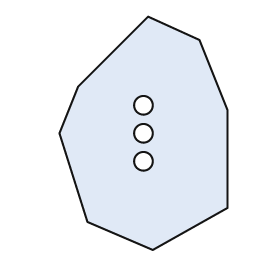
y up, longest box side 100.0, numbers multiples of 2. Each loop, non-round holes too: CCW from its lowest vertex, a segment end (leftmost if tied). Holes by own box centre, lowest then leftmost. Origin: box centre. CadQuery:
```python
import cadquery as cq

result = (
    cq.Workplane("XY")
    .moveTo(4.0, -50.0)
    .lineTo(36.0, -32.0)
    .lineTo(36.0, 10.0)
    .lineTo(24.0, 40.0)
    .lineTo(2.0, 50.0)
    .lineTo(-28.0, 20.0)
    .lineTo(-36.0, 0.0)
    .lineTo(-24.0, -38.0)
    .close()
    .moveTo(0.0, -12.0)
    .circle(4.0)
    .moveTo(0.0, 0.0)
    .circle(4.0)
    .moveTo(0.0, 12.0)
    .circle(4.0)
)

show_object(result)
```